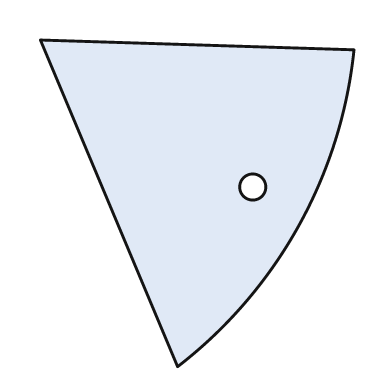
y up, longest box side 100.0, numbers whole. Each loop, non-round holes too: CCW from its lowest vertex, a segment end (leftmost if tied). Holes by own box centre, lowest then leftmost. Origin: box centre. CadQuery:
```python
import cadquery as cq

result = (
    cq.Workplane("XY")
    .moveTo(-6.0, -50.0)
    .threePointArc((31.0, -7.0), (48.0, 47.0))
    .lineTo(-48.0, 50.0)
    .close()
    .moveTo(17.0, 5.0)
    .circle(4.0)
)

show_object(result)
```